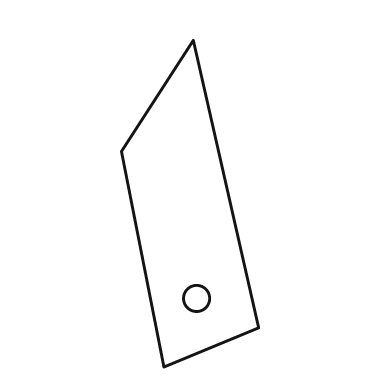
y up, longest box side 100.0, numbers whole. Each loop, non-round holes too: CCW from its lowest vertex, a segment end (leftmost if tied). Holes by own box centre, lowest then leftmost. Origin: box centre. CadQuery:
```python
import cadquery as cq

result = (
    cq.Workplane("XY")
    .moveTo(-8.0, -50.0)
    .lineTo(21.0, -38.0)
    .lineTo(1.0, 50.0)
    .lineTo(-21.0, 16.0)
    .close()
    .moveTo(2.0, -29.0)
    .circle(4.0)
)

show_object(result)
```